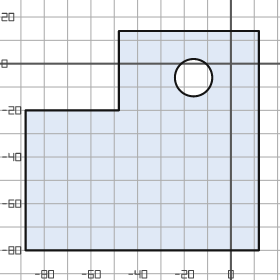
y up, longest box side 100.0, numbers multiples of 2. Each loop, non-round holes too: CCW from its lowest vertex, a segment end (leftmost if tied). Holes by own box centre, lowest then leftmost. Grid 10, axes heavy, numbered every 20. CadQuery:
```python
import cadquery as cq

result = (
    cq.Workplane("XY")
    .moveTo(-88.0, -80.0)
    .lineTo(12.0, -80.0)
    .lineTo(12.0, 14.0)
    .lineTo(-48.0, 14.0)
    .lineTo(-48.0, -20.0)
    .lineTo(-88.0, -20.0)
    .close()
    .moveTo(-16.0, -6.0)
    .circle(8.0)
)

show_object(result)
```